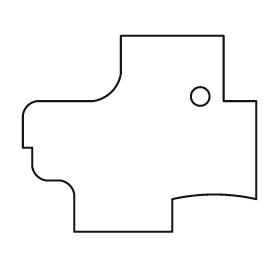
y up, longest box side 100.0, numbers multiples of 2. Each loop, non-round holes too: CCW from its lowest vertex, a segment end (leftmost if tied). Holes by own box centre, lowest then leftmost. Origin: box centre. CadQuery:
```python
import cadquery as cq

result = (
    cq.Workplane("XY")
    .moveTo(-28.0, -42.0)
    .lineTo(14.0, -42.0)
    .lineTo(14.0, -28.0)
    .threePointArc((32.0, -26.0), (50.0, -28.0))
    .lineTo(50.0, 14.0)
    .lineTo(36.0, 14.0)
    .lineTo(36.0, 42.0)
    .lineTo(-8.0, 42.0)
    .lineTo(-8.0, 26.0)
    .threePointArc((-12.0, 18.0), (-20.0, 14.0))
    .lineTo(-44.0, 14.0)
    .threePointArc((-48.0, 12.0), (-50.0, 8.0))
    .lineTo(-50.0, -6.0)
    .lineTo(-46.0, -6.0)
    .lineTo(-46.0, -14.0)
    .threePointArc((-44.0, -18.0), (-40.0, -20.0))
    .lineTo(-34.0, -20.0)
    .threePointArc((-30.0, -22.0), (-28.0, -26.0))
    .close()
    .moveTo(26.0, 16.0)
    .circle(4.0)
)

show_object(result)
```